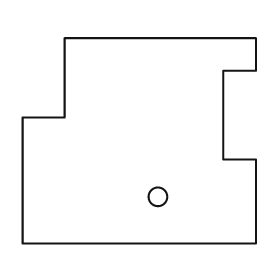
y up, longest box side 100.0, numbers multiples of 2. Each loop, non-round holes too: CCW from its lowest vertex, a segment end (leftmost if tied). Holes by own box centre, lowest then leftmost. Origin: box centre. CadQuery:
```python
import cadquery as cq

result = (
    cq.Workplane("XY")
    .moveTo(-50.0, -44.0)
    .lineTo(50.0, -44.0)
    .lineTo(50.0, -8.0)
    .lineTo(36.0, -8.0)
    .lineTo(36.0, 30.0)
    .lineTo(50.0, 30.0)
    .lineTo(50.0, 44.0)
    .lineTo(-32.0, 44.0)
    .lineTo(-32.0, 10.0)
    .lineTo(-50.0, 10.0)
    .close()
    .moveTo(8.0, -24.0)
    .circle(4.0)
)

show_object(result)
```